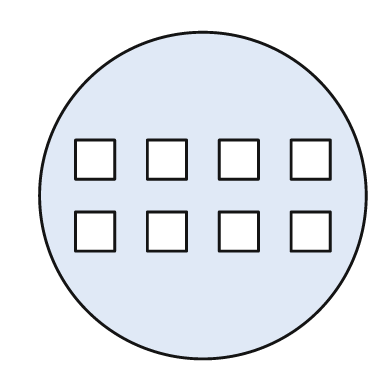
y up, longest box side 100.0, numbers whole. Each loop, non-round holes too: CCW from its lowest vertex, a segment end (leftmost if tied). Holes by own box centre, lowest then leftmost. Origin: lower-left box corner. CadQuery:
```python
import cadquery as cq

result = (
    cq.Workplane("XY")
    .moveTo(50.0, 50.0)
    .circle(50.0)
    .moveTo(11.0, 33.0)
    .lineTo(23.0, 33.0)
    .lineTo(23.0, 45.0)
    .lineTo(11.0, 45.0)
    .close()
    .moveTo(33.0, 33.0)
    .lineTo(45.0, 33.0)
    .lineTo(45.0, 45.0)
    .lineTo(33.0, 45.0)
    .close()
    .moveTo(55.0, 33.0)
    .lineTo(67.0, 33.0)
    .lineTo(67.0, 45.0)
    .lineTo(55.0, 45.0)
    .close()
    .moveTo(77.0, 33.0)
    .lineTo(89.0, 33.0)
    .lineTo(89.0, 45.0)
    .lineTo(77.0, 45.0)
    .close()
    .moveTo(11.0, 55.0)
    .lineTo(23.0, 55.0)
    .lineTo(23.0, 67.0)
    .lineTo(11.0, 67.0)
    .close()
    .moveTo(33.0, 55.0)
    .lineTo(45.0, 55.0)
    .lineTo(45.0, 67.0)
    .lineTo(33.0, 67.0)
    .close()
    .moveTo(55.0, 55.0)
    .lineTo(67.0, 55.0)
    .lineTo(67.0, 67.0)
    .lineTo(55.0, 67.0)
    .close()
    .moveTo(77.0, 55.0)
    .lineTo(89.0, 55.0)
    .lineTo(89.0, 67.0)
    .lineTo(77.0, 67.0)
    .close()
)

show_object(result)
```